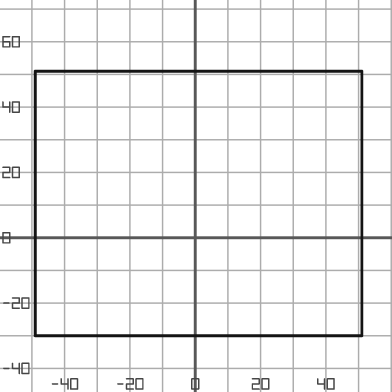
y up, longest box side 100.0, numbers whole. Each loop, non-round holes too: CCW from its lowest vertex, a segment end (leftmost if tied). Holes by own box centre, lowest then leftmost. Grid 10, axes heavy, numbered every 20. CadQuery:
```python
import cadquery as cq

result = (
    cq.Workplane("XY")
    .moveTo(-49.0, -30.0)
    .lineTo(51.0, -30.0)
    .lineTo(51.0, 51.0)
    .lineTo(-49.0, 51.0)
    .close()
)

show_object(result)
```